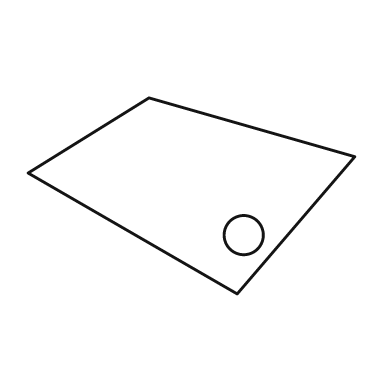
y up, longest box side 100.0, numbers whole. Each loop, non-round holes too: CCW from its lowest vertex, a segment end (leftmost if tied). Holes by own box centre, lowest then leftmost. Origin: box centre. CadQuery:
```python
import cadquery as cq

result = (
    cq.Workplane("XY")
    .moveTo(14.0, -30.0)
    .lineTo(50.0, 12.0)
    .lineTo(-13.0, 30.0)
    .lineTo(-50.0, 7.0)
    .close()
    .moveTo(16.0, -12.0)
    .circle(6.0)
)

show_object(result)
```